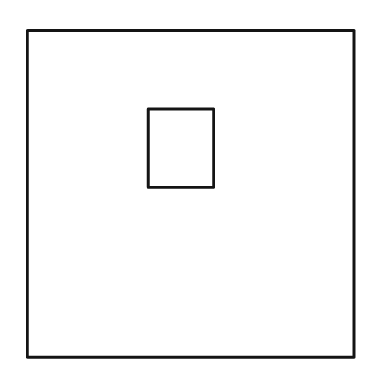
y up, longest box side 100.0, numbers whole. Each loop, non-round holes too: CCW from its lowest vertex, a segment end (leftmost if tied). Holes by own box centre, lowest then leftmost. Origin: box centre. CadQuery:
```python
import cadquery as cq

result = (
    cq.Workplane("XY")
    .moveTo(-50.0, -50.0)
    .lineTo(50.0, -50.0)
    .lineTo(50.0, 50.0)
    .lineTo(-50.0, 50.0)
    .close()
    .moveTo(-13.0, 2.0)
    .lineTo(7.0, 2.0)
    .lineTo(7.0, 26.0)
    .lineTo(-13.0, 26.0)
    .close()
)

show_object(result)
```